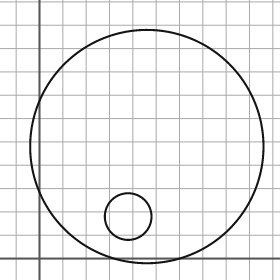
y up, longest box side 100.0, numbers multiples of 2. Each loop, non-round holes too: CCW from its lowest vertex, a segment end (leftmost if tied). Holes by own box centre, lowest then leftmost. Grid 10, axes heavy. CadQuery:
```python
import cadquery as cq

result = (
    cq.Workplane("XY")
    .moveTo(46.0, 48.0)
    .circle(50.0)
    .moveTo(38.0, 18.0)
    .circle(10.0)
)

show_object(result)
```